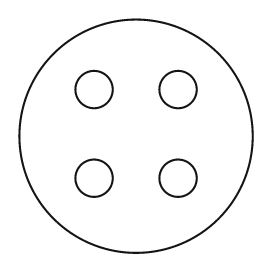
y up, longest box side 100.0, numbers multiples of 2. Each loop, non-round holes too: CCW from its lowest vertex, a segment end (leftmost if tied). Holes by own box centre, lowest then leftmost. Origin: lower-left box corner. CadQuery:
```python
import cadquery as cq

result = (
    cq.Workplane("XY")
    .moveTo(50.0, 50.0)
    .circle(50.0)
    .moveTo(32.0, 32.0)
    .circle(8.0)
    .moveTo(68.0, 32.0)
    .circle(8.0)
    .moveTo(32.0, 70.0)
    .circle(8.0)
    .moveTo(68.0, 70.0)
    .circle(8.0)
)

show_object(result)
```